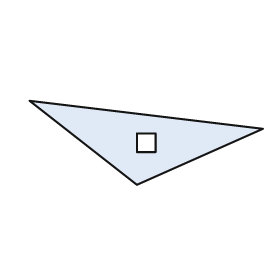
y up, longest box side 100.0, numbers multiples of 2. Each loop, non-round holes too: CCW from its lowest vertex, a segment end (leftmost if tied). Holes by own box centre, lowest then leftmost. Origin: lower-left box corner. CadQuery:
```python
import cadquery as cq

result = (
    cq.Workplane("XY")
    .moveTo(46.0, 0.0)
    .lineTo(100.0, 24.0)
    .lineTo(0.0, 36.0)
    .close()
    .moveTo(46.0, 14.0)
    .lineTo(54.0, 14.0)
    .lineTo(54.0, 22.0)
    .lineTo(46.0, 22.0)
    .close()
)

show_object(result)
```